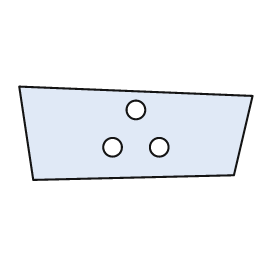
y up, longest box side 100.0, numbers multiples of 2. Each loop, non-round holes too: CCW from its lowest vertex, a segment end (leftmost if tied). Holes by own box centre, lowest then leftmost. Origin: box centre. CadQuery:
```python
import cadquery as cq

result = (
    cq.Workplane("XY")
    .moveTo(-44.0, -20.0)
    .lineTo(42.0, -18.0)
    .lineTo(50.0, 16.0)
    .lineTo(-50.0, 20.0)
    .close()
    .moveTo(-10.0, -6.0)
    .circle(4.0)
    .moveTo(10.0, -6.0)
    .circle(4.0)
    .moveTo(0.0, 10.0)
    .circle(4.0)
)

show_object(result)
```